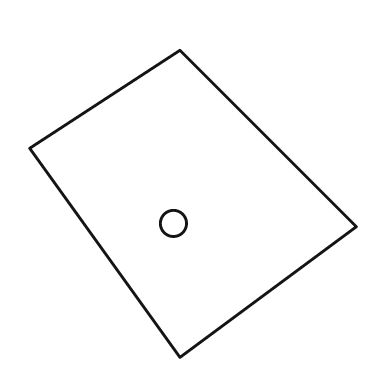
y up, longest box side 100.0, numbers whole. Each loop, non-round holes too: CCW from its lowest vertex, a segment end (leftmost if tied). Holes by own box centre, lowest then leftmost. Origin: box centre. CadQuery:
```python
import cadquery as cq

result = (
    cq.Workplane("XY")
    .moveTo(-4.0, -47.0)
    .lineTo(50.0, -7.0)
    .lineTo(-4.0, 47.0)
    .lineTo(-50.0, 17.0)
    .close()
    .moveTo(-6.0, -6.0)
    .circle(4.0)
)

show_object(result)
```